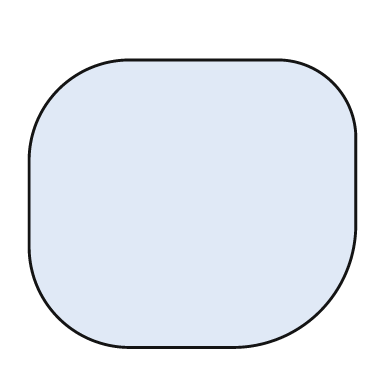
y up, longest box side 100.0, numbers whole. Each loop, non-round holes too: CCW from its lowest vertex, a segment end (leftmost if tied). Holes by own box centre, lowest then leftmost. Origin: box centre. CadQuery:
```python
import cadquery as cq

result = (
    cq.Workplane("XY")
    .moveTo(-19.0, -44.0)
    .lineTo(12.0, -44.0)
    .threePointArc((39.0, -33.0), (50.0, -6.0))
    .lineTo(50.0, 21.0)
    .threePointArc((43.0, 37.0), (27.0, 44.0))
    .lineTo(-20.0, 44.0)
    .threePointArc((-41.0, 35.0), (-50.0, 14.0))
    .lineTo(-50.0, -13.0)
    .threePointArc((-41.0, -35.0), (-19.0, -44.0))
    .close()
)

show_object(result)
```